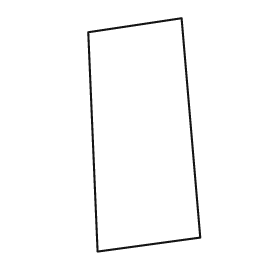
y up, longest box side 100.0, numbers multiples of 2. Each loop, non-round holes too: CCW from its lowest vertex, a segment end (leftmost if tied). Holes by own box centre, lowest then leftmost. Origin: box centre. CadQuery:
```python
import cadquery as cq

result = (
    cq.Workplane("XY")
    .moveTo(-20.0, -50.0)
    .lineTo(24.0, -44.0)
    .lineTo(16.0, 50.0)
    .lineTo(-24.0, 44.0)
    .close()
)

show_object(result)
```